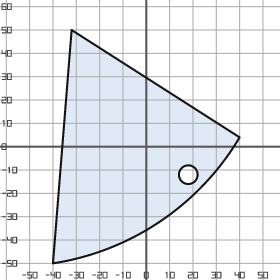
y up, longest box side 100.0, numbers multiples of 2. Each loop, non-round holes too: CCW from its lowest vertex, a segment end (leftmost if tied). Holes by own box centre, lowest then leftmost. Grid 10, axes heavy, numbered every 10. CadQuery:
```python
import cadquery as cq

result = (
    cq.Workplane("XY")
    .moveTo(-40.0, -50.0)
    .threePointArc((6.0, -32.0), (40.0, 4.0))
    .lineTo(-32.0, 50.0)
    .close()
    .moveTo(18.0, -12.0)
    .circle(4.0)
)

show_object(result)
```